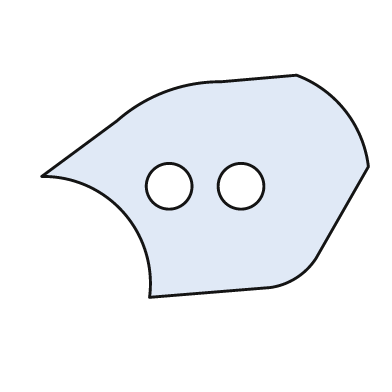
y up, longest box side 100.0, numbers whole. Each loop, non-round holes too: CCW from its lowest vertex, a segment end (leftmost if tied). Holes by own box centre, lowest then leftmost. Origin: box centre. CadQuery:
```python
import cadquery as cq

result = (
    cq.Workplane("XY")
    .moveTo(-17.0, -34.0)
    .lineTo(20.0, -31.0)
    .threePointArc((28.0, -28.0), (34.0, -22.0))
    .lineTo(50.0, 6.0)
    .threePointArc((43.0, 23.0), (28.0, 34.0))
    .lineTo(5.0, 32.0)
    .threePointArc((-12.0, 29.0), (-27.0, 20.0))
    .lineTo(-50.0, 3.0)
    .threePointArc((-25.0, -8.0), (-17.0, -34.0))
    .close()
    .moveTo(-11.0, 0.0)
    .circle(7.0)
    .moveTo(11.0, 0.0)
    .circle(7.0)
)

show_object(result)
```